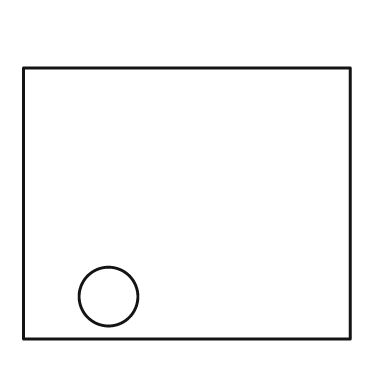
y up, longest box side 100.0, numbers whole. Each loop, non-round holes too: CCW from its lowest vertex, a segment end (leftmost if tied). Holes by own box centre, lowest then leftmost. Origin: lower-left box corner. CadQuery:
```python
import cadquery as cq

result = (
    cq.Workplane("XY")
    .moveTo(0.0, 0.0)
    .lineTo(100.0, 0.0)
    .lineTo(100.0, 83.0)
    .lineTo(0.0, 83.0)
    .close()
    .moveTo(26.0, 13.0)
    .circle(9.0)
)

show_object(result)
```